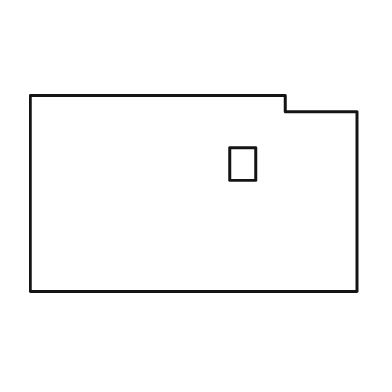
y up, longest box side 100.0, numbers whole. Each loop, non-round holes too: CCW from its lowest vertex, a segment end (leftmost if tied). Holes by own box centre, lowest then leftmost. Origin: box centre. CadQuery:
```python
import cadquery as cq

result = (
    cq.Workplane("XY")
    .moveTo(-50.0, -30.0)
    .lineTo(50.0, -30.0)
    .lineTo(50.0, 25.0)
    .lineTo(28.0, 25.0)
    .lineTo(28.0, 30.0)
    .lineTo(-50.0, 30.0)
    .close()
    .moveTo(11.0, 4.0)
    .lineTo(19.0, 4.0)
    .lineTo(19.0, 14.0)
    .lineTo(11.0, 14.0)
    .close()
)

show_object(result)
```